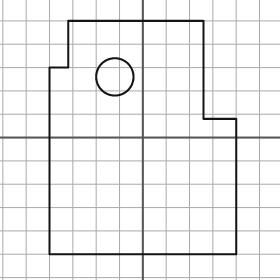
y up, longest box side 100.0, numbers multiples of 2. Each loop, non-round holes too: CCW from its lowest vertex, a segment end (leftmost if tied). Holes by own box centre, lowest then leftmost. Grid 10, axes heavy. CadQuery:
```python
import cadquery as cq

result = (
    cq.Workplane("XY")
    .moveTo(-40.0, -50.0)
    .lineTo(40.0, -50.0)
    .lineTo(40.0, 8.0)
    .lineTo(26.0, 8.0)
    .lineTo(26.0, 50.0)
    .lineTo(-32.0, 50.0)
    .lineTo(-32.0, 30.0)
    .lineTo(-40.0, 30.0)
    .close()
    .moveTo(-12.0, 26.0)
    .circle(8.0)
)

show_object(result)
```